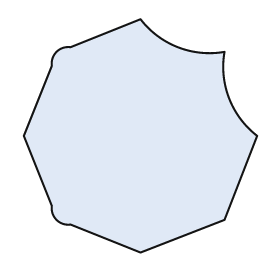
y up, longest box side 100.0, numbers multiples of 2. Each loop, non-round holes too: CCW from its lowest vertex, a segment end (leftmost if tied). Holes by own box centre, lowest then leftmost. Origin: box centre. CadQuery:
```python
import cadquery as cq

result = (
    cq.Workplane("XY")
    .moveTo(0.0, -50.0)
    .lineTo(36.0, -36.0)
    .lineTo(50.0, 0.0)
    .threePointArc((38.0, 16.0), (36.0, 36.0))
    .threePointArc((16.0, 38.0), (0.0, 50.0))
    .lineTo(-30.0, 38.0)
    .threePointArc((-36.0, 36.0), (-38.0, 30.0))
    .lineTo(-50.0, 0.0)
    .lineTo(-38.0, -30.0)
    .threePointArc((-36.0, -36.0), (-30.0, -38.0))
    .close()
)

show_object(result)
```